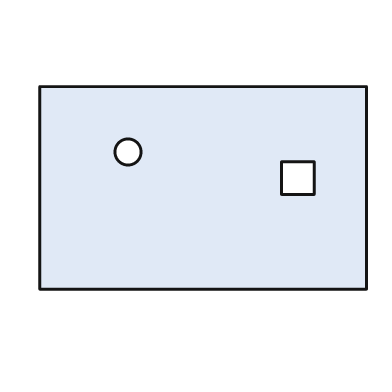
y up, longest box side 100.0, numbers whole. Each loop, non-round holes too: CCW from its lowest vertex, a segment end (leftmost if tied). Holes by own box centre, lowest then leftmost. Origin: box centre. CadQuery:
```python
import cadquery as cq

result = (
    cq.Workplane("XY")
    .moveTo(-50.0, -31.0)
    .lineTo(50.0, -31.0)
    .lineTo(50.0, 31.0)
    .lineTo(-50.0, 31.0)
    .close()
    .moveTo(24.0, -2.0)
    .lineTo(34.0, -2.0)
    .lineTo(34.0, 8.0)
    .lineTo(24.0, 8.0)
    .close()
    .moveTo(-23.0, 11.0)
    .circle(4.0)
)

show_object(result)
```